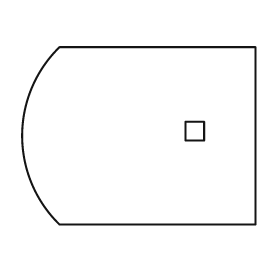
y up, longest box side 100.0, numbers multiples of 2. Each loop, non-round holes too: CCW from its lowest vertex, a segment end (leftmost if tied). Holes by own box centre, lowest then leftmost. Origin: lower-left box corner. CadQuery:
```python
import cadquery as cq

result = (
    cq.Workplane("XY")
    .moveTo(16.0, 0.0)
    .lineTo(100.0, 0.0)
    .lineTo(100.0, 76.0)
    .lineTo(16.0, 76.0)
    .threePointArc((0.0, 38.0), (16.0, 0.0))
    .close()
    .moveTo(70.0, 36.0)
    .lineTo(78.0, 36.0)
    .lineTo(78.0, 44.0)
    .lineTo(70.0, 44.0)
    .close()
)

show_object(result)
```